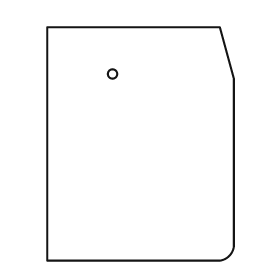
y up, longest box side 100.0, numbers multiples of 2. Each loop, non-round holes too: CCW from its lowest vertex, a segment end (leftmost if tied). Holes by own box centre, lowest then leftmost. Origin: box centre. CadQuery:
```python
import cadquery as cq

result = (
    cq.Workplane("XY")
    .moveTo(-40.0, -50.0)
    .lineTo(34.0, -50.0)
    .threePointArc((38.0, -48.0), (40.0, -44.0))
    .lineTo(40.0, 28.0)
    .lineTo(34.0, 50.0)
    .lineTo(-40.0, 50.0)
    .close()
    .moveTo(-12.0, 30.0)
    .circle(2.0)
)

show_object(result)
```